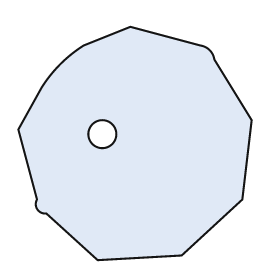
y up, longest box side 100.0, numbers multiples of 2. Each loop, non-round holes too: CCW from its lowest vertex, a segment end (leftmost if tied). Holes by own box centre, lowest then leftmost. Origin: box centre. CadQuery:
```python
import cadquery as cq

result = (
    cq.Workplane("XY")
    .moveTo(-16.0, -50.0)
    .lineTo(20.0, -48.0)
    .lineTo(46.0, -24.0)
    .lineTo(50.0, 10.0)
    .lineTo(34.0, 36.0)
    .threePointArc((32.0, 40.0), (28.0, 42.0))
    .lineTo(-2.0, 50.0)
    .lineTo(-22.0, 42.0)
    .threePointArc((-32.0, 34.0), (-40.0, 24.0))
    .lineTo(-50.0, 6.0)
    .lineTo(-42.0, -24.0)
    .threePointArc((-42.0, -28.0), (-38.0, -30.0))
    .close()
    .moveTo(-14.0, 4.0)
    .circle(6.0)
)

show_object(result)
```